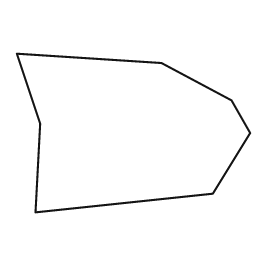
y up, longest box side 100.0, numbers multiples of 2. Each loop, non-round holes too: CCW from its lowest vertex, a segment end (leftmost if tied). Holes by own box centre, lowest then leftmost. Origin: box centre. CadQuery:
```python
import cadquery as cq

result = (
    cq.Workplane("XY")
    .moveTo(-42.0, -34.0)
    .lineTo(34.0, -26.0)
    .lineTo(50.0, 0.0)
    .lineTo(42.0, 14.0)
    .lineTo(12.0, 30.0)
    .lineTo(-50.0, 34.0)
    .lineTo(-40.0, 4.0)
    .close()
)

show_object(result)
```